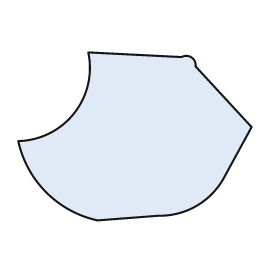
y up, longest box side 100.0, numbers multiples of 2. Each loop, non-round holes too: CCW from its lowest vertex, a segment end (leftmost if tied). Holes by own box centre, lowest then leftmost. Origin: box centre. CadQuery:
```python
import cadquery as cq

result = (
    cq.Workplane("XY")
    .moveTo(-16.0, -36.0)
    .lineTo(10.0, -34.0)
    .threePointArc((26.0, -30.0), (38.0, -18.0))
    .lineTo(50.0, 4.0)
    .lineTo(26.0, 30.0)
    .threePointArc((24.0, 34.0), (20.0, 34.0))
    .lineTo(-20.0, 36.0)
    .threePointArc((-26.0, 10.0), (-50.0, -2.0))
    .threePointArc((-38.0, -24.0), (-16.0, -36.0))
    .close()
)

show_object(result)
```